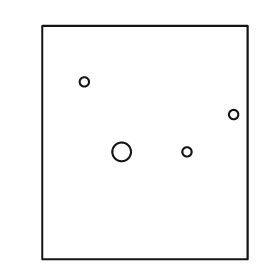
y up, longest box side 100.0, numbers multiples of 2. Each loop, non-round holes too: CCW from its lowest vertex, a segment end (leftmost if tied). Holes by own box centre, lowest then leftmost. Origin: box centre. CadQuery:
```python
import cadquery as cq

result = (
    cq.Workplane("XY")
    .moveTo(-44.0, -50.0)
    .lineTo(44.0, -50.0)
    .lineTo(44.0, 50.0)
    .lineTo(-44.0, 50.0)
    .close()
    .moveTo(-10.0, -4.0)
    .circle(4.0)
    .moveTo(18.0, -4.0)
    .circle(2.0)
    .moveTo(38.0, 12.0)
    .circle(2.0)
    .moveTo(-26.0, 26.0)
    .circle(2.0)
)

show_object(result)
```